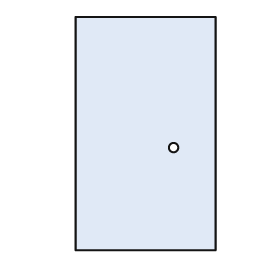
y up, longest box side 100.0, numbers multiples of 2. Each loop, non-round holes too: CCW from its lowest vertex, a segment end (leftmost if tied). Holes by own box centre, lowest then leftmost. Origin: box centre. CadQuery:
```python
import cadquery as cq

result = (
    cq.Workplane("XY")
    .moveTo(-30.0, -50.0)
    .lineTo(30.0, -50.0)
    .lineTo(30.0, 50.0)
    .lineTo(-30.0, 50.0)
    .close()
    .moveTo(12.0, -6.0)
    .circle(2.0)
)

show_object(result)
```